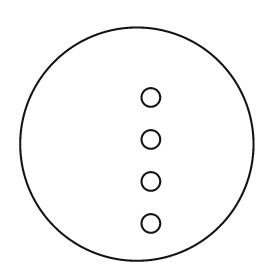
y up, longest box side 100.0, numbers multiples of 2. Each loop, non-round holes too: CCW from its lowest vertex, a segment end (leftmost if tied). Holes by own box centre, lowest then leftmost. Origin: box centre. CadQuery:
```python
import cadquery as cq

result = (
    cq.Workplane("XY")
    .moveTo(0.0, 0.0)
    .circle(50.0)
    .moveTo(6.0, -34.0)
    .circle(4.0)
    .moveTo(6.0, -16.0)
    .circle(4.0)
    .moveTo(6.0, 2.0)
    .circle(4.0)
    .moveTo(6.0, 20.0)
    .circle(4.0)
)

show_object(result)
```